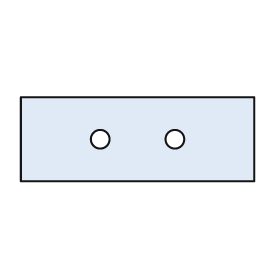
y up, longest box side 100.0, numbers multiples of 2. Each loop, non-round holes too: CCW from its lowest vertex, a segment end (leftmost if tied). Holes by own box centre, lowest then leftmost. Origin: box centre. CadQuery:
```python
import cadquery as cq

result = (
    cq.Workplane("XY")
    .moveTo(-50.0, -18.0)
    .lineTo(50.0, -18.0)
    .lineTo(50.0, 18.0)
    .lineTo(-50.0, 18.0)
    .close()
    .moveTo(-16.0, 0.0)
    .circle(4.0)
    .moveTo(16.0, 0.0)
    .circle(4.0)
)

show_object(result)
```